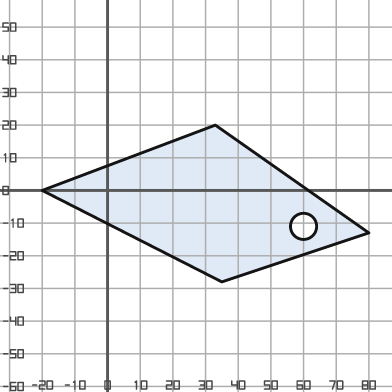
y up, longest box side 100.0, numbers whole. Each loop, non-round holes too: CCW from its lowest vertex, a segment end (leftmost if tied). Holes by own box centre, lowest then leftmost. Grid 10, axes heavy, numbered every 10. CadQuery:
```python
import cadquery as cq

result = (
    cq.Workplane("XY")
    .moveTo(35.0, -28.0)
    .lineTo(80.0, -13.0)
    .lineTo(33.0, 20.0)
    .lineTo(-20.0, 0.0)
    .close()
    .moveTo(60.0, -11.0)
    .circle(4.0)
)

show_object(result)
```